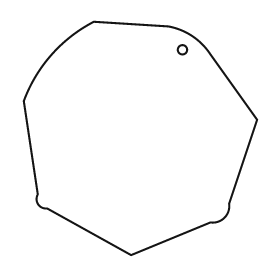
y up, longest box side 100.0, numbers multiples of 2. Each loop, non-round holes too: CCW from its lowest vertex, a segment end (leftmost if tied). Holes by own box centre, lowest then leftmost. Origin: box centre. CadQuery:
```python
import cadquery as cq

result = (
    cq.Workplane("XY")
    .moveTo(-4.0, -50.0)
    .lineTo(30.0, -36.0)
    .threePointArc((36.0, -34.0), (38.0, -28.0))
    .lineTo(50.0, 8.0)
    .lineTo(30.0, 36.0)
    .threePointArc((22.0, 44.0), (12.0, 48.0))
    .lineTo(-20.0, 50.0)
    .threePointArc((-38.0, 36.0), (-50.0, 16.0))
    .lineTo(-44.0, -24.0)
    .threePointArc((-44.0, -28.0), (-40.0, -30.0))
    .close()
    .moveTo(18.0, 38.0)
    .circle(2.0)
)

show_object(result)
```